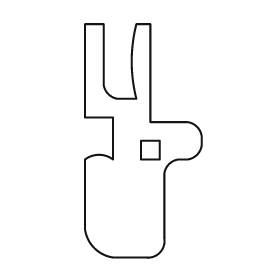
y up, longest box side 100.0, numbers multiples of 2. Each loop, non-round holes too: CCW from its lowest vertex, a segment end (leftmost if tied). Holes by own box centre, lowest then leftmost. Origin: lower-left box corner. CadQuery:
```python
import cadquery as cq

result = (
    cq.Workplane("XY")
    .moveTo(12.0, 0.0)
    .lineTo(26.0, 0.0)
    .threePointArc((32.0, 2.0), (34.0, 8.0))
    .lineTo(34.0, 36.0)
    .threePointArc((36.0, 40.0), (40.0, 42.0))
    .lineTo(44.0, 42.0)
    .threePointArc((48.0, 44.0), (50.0, 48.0))
    .lineTo(50.0, 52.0)
    .threePointArc((48.0, 56.0), (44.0, 58.0))
    .lineTo(28.0, 58.0)
    .lineTo(28.0, 100.0)
    .lineTo(22.0, 100.0)
    .threePointArc((20.0, 84.0), (22.0, 68.0))
    .lineTo(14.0, 68.0)
    .threePointArc((10.0, 70.0), (8.0, 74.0))
    .lineTo(8.0, 100.0)
    .lineTo(0.0, 100.0)
    .lineTo(0.0, 60.0)
    .lineTo(12.0, 60.0)
    .lineTo(12.0, 42.0)
    .threePointArc((6.0, 44.0), (0.0, 42.0))
    .lineTo(0.0, 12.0)
    .threePointArc((4.0, 4.0), (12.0, 0.0))
    .close()
    .moveTo(24.0, 42.0)
    .lineTo(32.0, 42.0)
    .lineTo(32.0, 50.0)
    .lineTo(24.0, 50.0)
    .close()
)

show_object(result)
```